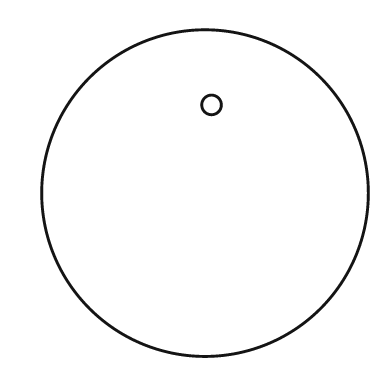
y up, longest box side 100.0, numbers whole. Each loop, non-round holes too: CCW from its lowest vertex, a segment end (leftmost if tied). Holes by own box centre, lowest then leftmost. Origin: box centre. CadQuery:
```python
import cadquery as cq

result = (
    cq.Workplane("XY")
    .moveTo(0.0, 0.0)
    .circle(50.0)
    .moveTo(2.0, 27.0)
    .circle(3.0)
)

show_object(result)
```